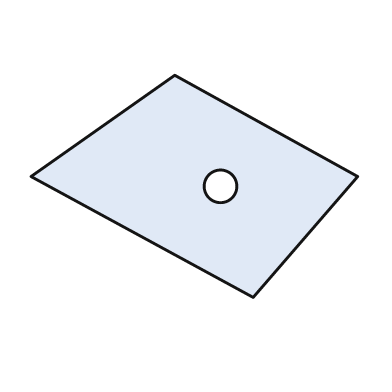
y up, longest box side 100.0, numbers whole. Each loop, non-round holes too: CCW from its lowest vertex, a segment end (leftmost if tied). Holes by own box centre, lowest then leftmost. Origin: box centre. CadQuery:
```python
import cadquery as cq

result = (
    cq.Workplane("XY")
    .moveTo(18.0, -34.0)
    .lineTo(50.0, 3.0)
    .lineTo(-6.0, 34.0)
    .lineTo(-50.0, 3.0)
    .close()
    .moveTo(8.0, 0.0)
    .circle(5.0)
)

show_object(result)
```